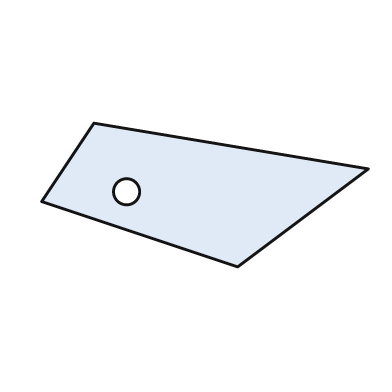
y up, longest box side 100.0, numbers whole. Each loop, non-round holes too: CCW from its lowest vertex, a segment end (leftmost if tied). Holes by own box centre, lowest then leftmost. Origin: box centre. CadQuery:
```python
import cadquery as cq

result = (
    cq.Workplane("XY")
    .moveTo(10.0, -22.0)
    .lineTo(50.0, 8.0)
    .lineTo(-34.0, 22.0)
    .lineTo(-50.0, -2.0)
    .close()
    .moveTo(-24.0, 1.0)
    .circle(4.0)
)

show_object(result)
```